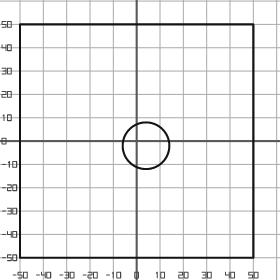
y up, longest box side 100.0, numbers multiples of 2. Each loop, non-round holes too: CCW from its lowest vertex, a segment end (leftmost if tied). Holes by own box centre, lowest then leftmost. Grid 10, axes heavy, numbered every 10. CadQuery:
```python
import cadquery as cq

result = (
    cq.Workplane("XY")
    .moveTo(-50.0, -50.0)
    .lineTo(50.0, -50.0)
    .lineTo(50.0, 50.0)
    .lineTo(-50.0, 50.0)
    .close()
    .moveTo(4.0, -2.0)
    .circle(10.0)
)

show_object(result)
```